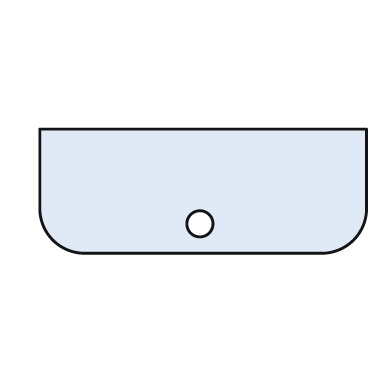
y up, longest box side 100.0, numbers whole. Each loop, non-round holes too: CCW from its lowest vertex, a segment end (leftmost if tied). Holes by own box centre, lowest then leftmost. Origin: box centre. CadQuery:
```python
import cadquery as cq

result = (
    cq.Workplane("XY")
    .moveTo(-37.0, -19.0)
    .lineTo(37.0, -19.0)
    .threePointArc((46.0, -15.0), (50.0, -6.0))
    .lineTo(50.0, 19.0)
    .lineTo(-50.0, 19.0)
    .lineTo(-50.0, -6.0)
    .threePointArc((-46.0, -15.0), (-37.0, -19.0))
    .close()
    .moveTo(-1.0, -10.0)
    .circle(4.0)
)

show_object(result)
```